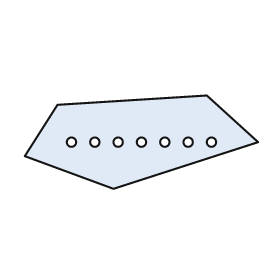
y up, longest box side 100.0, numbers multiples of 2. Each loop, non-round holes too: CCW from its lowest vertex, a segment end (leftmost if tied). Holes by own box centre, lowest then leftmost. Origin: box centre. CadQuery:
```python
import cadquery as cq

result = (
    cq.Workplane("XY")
    .moveTo(-12.0, -20.0)
    .lineTo(50.0, 0.0)
    .lineTo(28.0, 20.0)
    .lineTo(-36.0, 16.0)
    .lineTo(-50.0, -6.0)
    .close()
    .moveTo(-30.0, 0.0)
    .circle(2.0)
    .moveTo(-20.0, 0.0)
    .circle(2.0)
    .moveTo(-10.0, 0.0)
    .circle(2.0)
    .moveTo(0.0, 0.0)
    .circle(2.0)
    .moveTo(10.0, 0.0)
    .circle(2.0)
    .moveTo(20.0, 0.0)
    .circle(2.0)
    .moveTo(30.0, 0.0)
    .circle(2.0)
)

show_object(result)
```